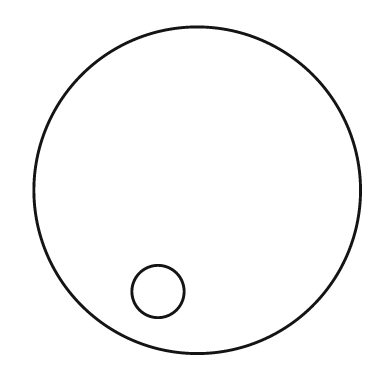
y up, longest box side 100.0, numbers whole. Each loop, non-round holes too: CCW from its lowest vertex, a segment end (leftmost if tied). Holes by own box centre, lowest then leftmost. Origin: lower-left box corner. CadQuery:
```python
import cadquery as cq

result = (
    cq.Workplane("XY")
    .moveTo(50.0, 50.0)
    .circle(50.0)
    .moveTo(38.0, 19.0)
    .circle(8.0)
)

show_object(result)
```